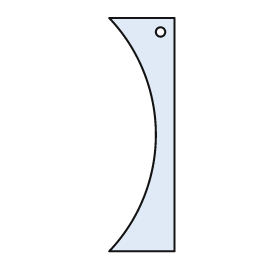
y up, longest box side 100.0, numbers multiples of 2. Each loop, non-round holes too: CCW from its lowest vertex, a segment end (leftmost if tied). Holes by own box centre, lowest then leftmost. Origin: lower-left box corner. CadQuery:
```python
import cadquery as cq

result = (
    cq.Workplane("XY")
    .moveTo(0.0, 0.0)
    .lineTo(28.0, 0.0)
    .lineTo(28.0, 100.0)
    .lineTo(0.0, 100.0)
    .threePointArc((20.0, 50.0), (0.0, 0.0))
    .close()
    .moveTo(22.0, 94.0)
    .circle(2.0)
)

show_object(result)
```